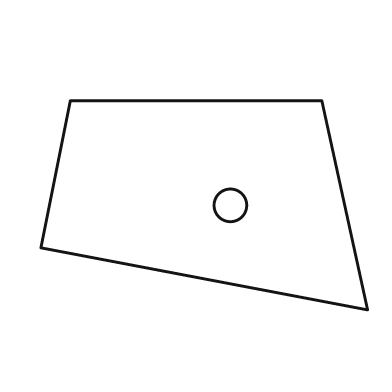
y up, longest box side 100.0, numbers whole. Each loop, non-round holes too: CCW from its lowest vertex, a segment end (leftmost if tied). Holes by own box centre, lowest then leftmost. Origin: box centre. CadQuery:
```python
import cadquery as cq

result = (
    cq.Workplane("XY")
    .moveTo(50.0, -32.0)
    .lineTo(36.0, 32.0)
    .lineTo(-41.0, 32.0)
    .lineTo(-50.0, -13.0)
    .close()
    .moveTo(8.0, 0.0)
    .circle(5.0)
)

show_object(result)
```